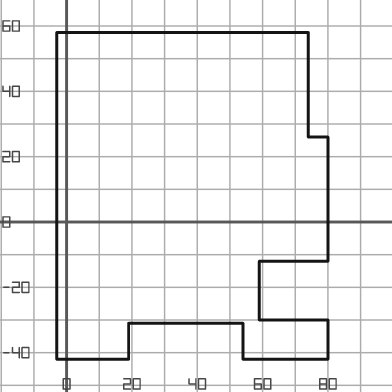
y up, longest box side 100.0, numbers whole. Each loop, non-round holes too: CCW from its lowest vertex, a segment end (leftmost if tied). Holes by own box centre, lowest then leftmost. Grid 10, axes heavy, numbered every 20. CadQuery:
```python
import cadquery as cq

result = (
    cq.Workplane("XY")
    .moveTo(-3.0, -42.0)
    .lineTo(19.0, -42.0)
    .lineTo(19.0, -31.0)
    .lineTo(54.0, -31.0)
    .lineTo(54.0, -42.0)
    .lineTo(80.0, -42.0)
    .lineTo(80.0, -30.0)
    .lineTo(59.0, -30.0)
    .lineTo(59.0, -12.0)
    .lineTo(80.0, -12.0)
    .lineTo(80.0, 26.0)
    .lineTo(74.0, 26.0)
    .lineTo(74.0, 58.0)
    .lineTo(-3.0, 58.0)
    .close()
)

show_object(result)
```